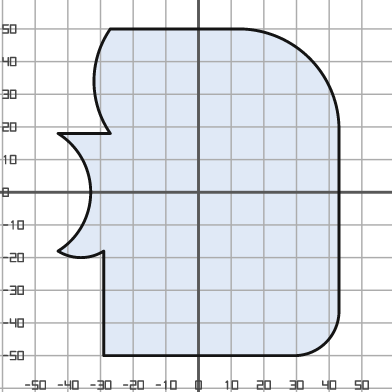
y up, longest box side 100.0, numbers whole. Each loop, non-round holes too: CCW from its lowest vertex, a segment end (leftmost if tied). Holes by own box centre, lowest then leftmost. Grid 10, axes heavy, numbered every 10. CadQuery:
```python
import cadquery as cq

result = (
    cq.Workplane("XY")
    .moveTo(-29.0, -50.0)
    .lineTo(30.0, -50.0)
    .threePointArc((39.0, -46.0), (43.0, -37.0))
    .lineTo(43.0, 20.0)
    .threePointArc((34.0, 41.0), (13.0, 50.0))
    .lineTo(-27.0, 50.0)
    .threePointArc((-32.0, 34.0), (-27.0, 18.0))
    .lineTo(-43.0, 18.0)
    .threePointArc((-33.0, 0.0), (-43.0, -18.0))
    .threePointArc((-36.0, -20.0), (-29.0, -18.0))
    .close()
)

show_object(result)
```